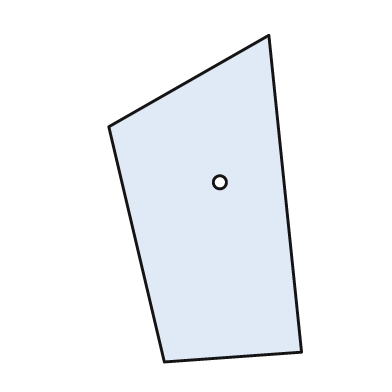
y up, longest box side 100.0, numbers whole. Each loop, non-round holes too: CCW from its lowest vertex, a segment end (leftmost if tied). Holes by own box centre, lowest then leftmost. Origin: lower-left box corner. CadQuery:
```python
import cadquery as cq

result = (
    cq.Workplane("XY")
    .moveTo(17.0, 0.0)
    .lineTo(59.0, 3.0)
    .lineTo(49.0, 100.0)
    .lineTo(0.0, 72.0)
    .close()
    .moveTo(34.0, 55.0)
    .circle(2.0)
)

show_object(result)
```